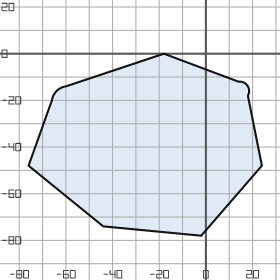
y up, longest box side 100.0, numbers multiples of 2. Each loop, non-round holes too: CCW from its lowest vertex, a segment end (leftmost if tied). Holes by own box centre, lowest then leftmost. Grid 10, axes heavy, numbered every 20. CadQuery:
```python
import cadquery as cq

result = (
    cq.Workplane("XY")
    .moveTo(-2.0, -78.0)
    .lineTo(24.0, -48.0)
    .lineTo(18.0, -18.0)
    .threePointArc((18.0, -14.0), (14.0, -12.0))
    .lineTo(-18.0, 0.0)
    .lineTo(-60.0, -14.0)
    .threePointArc((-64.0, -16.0), (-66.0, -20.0))
    .lineTo(-76.0, -48.0)
    .lineTo(-44.0, -74.0)
    .close()
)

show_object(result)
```